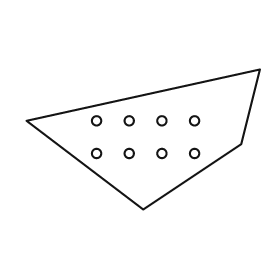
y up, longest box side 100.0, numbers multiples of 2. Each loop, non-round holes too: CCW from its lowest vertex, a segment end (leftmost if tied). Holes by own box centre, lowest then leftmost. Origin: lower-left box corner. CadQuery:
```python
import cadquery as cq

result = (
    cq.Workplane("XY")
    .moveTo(50.0, 0.0)
    .lineTo(92.0, 28.0)
    .lineTo(100.0, 60.0)
    .lineTo(0.0, 38.0)
    .close()
    .moveTo(30.0, 24.0)
    .circle(2.0)
    .moveTo(44.0, 24.0)
    .circle(2.0)
    .moveTo(58.0, 24.0)
    .circle(2.0)
    .moveTo(72.0, 24.0)
    .circle(2.0)
    .moveTo(30.0, 38.0)
    .circle(2.0)
    .moveTo(44.0, 38.0)
    .circle(2.0)
    .moveTo(58.0, 38.0)
    .circle(2.0)
    .moveTo(72.0, 38.0)
    .circle(2.0)
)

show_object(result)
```